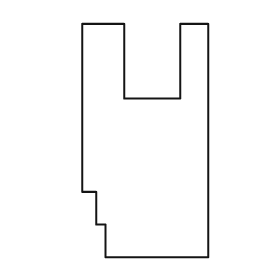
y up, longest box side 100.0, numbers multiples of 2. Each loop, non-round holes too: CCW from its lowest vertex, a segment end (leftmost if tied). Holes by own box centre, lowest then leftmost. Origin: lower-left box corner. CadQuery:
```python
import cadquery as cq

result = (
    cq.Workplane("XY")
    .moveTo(10.0, 0.0)
    .lineTo(54.0, 0.0)
    .lineTo(54.0, 100.0)
    .lineTo(42.0, 100.0)
    .lineTo(42.0, 68.0)
    .lineTo(18.0, 68.0)
    .lineTo(18.0, 100.0)
    .lineTo(0.0, 100.0)
    .lineTo(0.0, 28.0)
    .lineTo(6.0, 28.0)
    .lineTo(6.0, 14.0)
    .lineTo(10.0, 14.0)
    .close()
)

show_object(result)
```